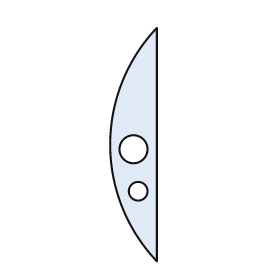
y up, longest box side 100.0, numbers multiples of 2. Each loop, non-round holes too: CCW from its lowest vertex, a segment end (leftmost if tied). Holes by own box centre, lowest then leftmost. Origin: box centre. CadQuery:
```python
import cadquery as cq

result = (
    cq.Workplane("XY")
    .moveTo(10.0, -50.0)
    .lineTo(10.0, 50.0)
    .threePointArc((-10.0, 0.0), (10.0, -50.0))
    .close()
    .moveTo(2.0, -20.0)
    .circle(4.0)
    .moveTo(0.0, -2.0)
    .circle(6.0)
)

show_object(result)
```